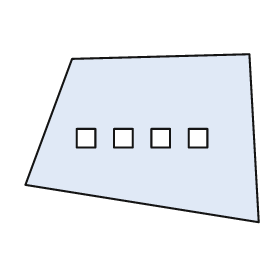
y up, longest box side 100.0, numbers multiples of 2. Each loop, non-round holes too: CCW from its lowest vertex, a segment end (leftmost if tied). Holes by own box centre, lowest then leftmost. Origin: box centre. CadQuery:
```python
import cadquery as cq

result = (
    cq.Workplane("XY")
    .moveTo(50.0, -36.0)
    .lineTo(46.0, 36.0)
    .lineTo(-30.0, 34.0)
    .lineTo(-50.0, -20.0)
    .close()
    .moveTo(-28.0, -4.0)
    .lineTo(-20.0, -4.0)
    .lineTo(-20.0, 4.0)
    .lineTo(-28.0, 4.0)
    .close()
    .moveTo(-12.0, -4.0)
    .lineTo(-4.0, -4.0)
    .lineTo(-4.0, 4.0)
    .lineTo(-12.0, 4.0)
    .close()
    .moveTo(4.0, -4.0)
    .lineTo(12.0, -4.0)
    .lineTo(12.0, 4.0)
    .lineTo(4.0, 4.0)
    .close()
    .moveTo(20.0, -4.0)
    .lineTo(28.0, -4.0)
    .lineTo(28.0, 4.0)
    .lineTo(20.0, 4.0)
    .close()
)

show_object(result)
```